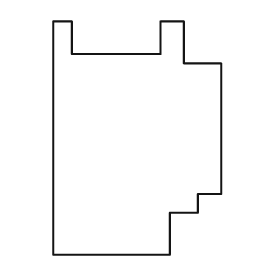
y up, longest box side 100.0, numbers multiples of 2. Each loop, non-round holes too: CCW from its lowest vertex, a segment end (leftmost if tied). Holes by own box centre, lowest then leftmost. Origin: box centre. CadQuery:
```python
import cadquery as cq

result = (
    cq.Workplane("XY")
    .moveTo(-36.0, -50.0)
    .lineTo(14.0, -50.0)
    .lineTo(14.0, -32.0)
    .lineTo(26.0, -32.0)
    .lineTo(26.0, -24.0)
    .lineTo(36.0, -24.0)
    .lineTo(36.0, 32.0)
    .lineTo(20.0, 32.0)
    .lineTo(20.0, 50.0)
    .lineTo(10.0, 50.0)
    .lineTo(10.0, 36.0)
    .lineTo(-28.0, 36.0)
    .lineTo(-28.0, 50.0)
    .lineTo(-36.0, 50.0)
    .close()
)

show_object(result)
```